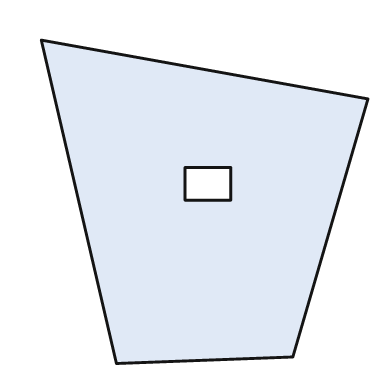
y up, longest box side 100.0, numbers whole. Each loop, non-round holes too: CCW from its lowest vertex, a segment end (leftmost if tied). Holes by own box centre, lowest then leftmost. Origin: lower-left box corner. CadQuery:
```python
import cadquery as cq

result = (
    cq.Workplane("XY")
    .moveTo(23.0, 0.0)
    .lineTo(77.0, 2.0)
    .lineTo(100.0, 81.0)
    .lineTo(0.0, 99.0)
    .close()
    .moveTo(44.0, 50.0)
    .lineTo(58.0, 50.0)
    .lineTo(58.0, 60.0)
    .lineTo(44.0, 60.0)
    .close()
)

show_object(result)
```